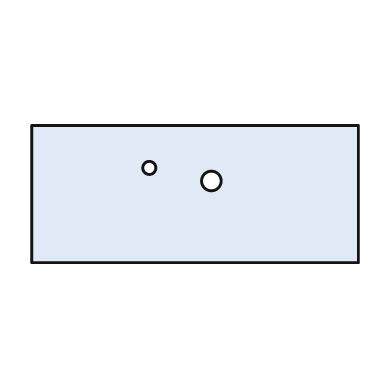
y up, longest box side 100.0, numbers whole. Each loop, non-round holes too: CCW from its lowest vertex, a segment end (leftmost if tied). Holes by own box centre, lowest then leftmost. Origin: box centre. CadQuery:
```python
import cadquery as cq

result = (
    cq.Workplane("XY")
    .moveTo(-50.0, -21.0)
    .lineTo(50.0, -21.0)
    .lineTo(50.0, 21.0)
    .lineTo(-50.0, 21.0)
    .close()
    .moveTo(5.0, 4.0)
    .circle(3.0)
    .moveTo(-14.0, 8.0)
    .circle(2.0)
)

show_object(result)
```